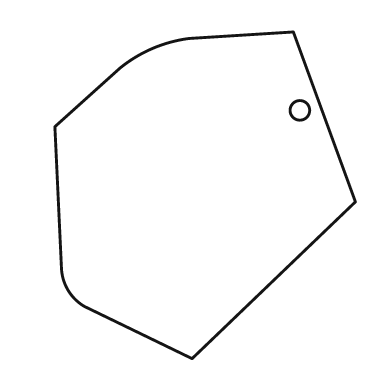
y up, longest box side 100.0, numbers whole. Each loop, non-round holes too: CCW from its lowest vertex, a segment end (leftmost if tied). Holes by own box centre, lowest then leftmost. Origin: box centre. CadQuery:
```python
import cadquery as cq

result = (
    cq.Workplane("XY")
    .moveTo(-4.0, -50.0)
    .lineTo(46.0, -2.0)
    .lineTo(27.0, 50.0)
    .lineTo(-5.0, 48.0)
    .threePointArc((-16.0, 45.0), (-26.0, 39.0))
    .lineTo(-46.0, 21.0)
    .lineTo(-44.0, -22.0)
    .threePointArc((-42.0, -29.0), (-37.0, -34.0))
    .close()
    .moveTo(29.0, 26.0)
    .circle(3.0)
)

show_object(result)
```